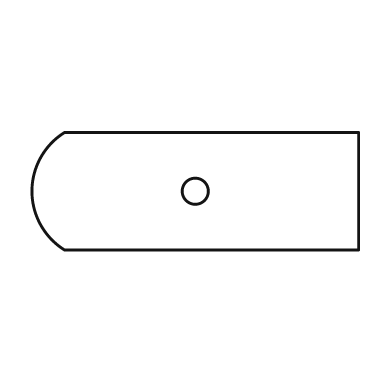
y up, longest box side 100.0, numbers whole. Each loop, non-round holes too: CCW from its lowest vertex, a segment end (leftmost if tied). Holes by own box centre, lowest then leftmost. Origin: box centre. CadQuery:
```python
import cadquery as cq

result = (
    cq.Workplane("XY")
    .moveTo(-40.0, -18.0)
    .lineTo(50.0, -18.0)
    .lineTo(50.0, 18.0)
    .lineTo(-40.0, 18.0)
    .threePointArc((-50.0, 0.0), (-40.0, -18.0))
    .close()
    .moveTo(0.0, 0.0)
    .circle(4.0)
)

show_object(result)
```